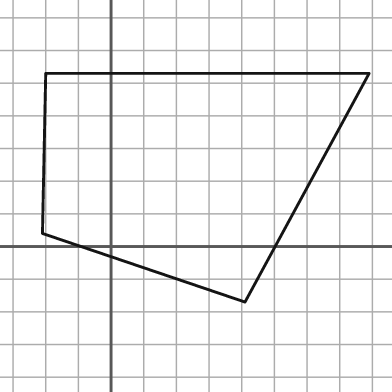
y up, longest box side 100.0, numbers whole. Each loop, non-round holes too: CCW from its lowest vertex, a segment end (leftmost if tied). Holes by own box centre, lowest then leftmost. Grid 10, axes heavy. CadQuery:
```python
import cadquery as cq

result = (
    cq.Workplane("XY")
    .moveTo(41.0, -17.0)
    .lineTo(79.0, 53.0)
    .lineTo(-20.0, 53.0)
    .lineTo(-21.0, 4.0)
    .close()
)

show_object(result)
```